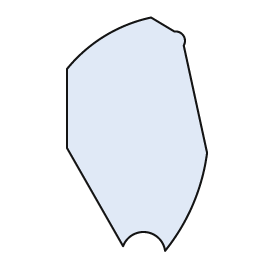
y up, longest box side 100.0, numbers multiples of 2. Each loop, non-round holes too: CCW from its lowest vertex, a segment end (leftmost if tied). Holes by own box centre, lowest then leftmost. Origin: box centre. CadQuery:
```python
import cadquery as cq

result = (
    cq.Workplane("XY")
    .moveTo(12.0, -50.0)
    .threePointArc((24.0, -30.0), (30.0, -8.0))
    .lineTo(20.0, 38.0)
    .threePointArc((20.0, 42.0), (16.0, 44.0))
    .lineTo(6.0, 50.0)
    .threePointArc((-14.0, 42.0), (-30.0, 28.0))
    .lineTo(-30.0, -6.0)
    .lineTo(-6.0, -48.0)
    .threePointArc((4.0, -42.0), (12.0, -50.0))
    .close()
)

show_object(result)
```